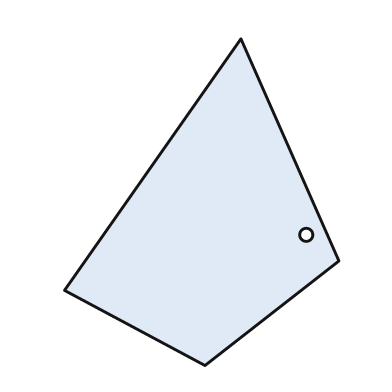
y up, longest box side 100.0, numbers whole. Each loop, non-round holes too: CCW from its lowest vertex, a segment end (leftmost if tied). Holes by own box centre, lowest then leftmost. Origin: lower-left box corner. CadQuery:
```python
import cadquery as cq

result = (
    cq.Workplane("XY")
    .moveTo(43.0, 0.0)
    .lineTo(84.0, 32.0)
    .lineTo(54.0, 100.0)
    .lineTo(0.0, 23.0)
    .close()
    .moveTo(74.0, 40.0)
    .circle(2.0)
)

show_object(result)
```